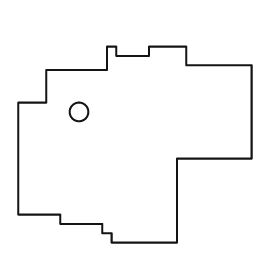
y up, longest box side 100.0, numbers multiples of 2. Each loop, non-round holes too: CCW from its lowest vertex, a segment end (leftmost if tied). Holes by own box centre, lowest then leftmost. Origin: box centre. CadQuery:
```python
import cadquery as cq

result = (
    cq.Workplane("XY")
    .moveTo(-10.0, -42.0)
    .lineTo(18.0, -42.0)
    .lineTo(18.0, -6.0)
    .lineTo(50.0, -6.0)
    .lineTo(50.0, 34.0)
    .lineTo(22.0, 34.0)
    .lineTo(22.0, 42.0)
    .lineTo(6.0, 42.0)
    .lineTo(6.0, 38.0)
    .lineTo(-8.0, 38.0)
    .lineTo(-8.0, 42.0)
    .lineTo(-12.0, 42.0)
    .lineTo(-12.0, 32.0)
    .lineTo(-38.0, 32.0)
    .lineTo(-38.0, 18.0)
    .lineTo(-50.0, 18.0)
    .lineTo(-50.0, -30.0)
    .lineTo(-32.0, -30.0)
    .lineTo(-32.0, -34.0)
    .lineTo(-14.0, -34.0)
    .lineTo(-14.0, -38.0)
    .lineTo(-10.0, -38.0)
    .close()
    .moveTo(-24.0, 14.0)
    .circle(4.0)
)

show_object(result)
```